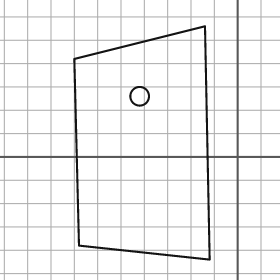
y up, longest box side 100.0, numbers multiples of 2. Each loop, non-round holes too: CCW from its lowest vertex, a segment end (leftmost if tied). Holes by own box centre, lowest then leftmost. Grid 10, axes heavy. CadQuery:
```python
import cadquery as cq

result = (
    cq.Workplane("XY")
    .moveTo(-12.0, -44.0)
    .lineTo(-14.0, 56.0)
    .lineTo(-70.0, 42.0)
    .lineTo(-68.0, -38.0)
    .close()
    .moveTo(-42.0, 26.0)
    .circle(4.0)
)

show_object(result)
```